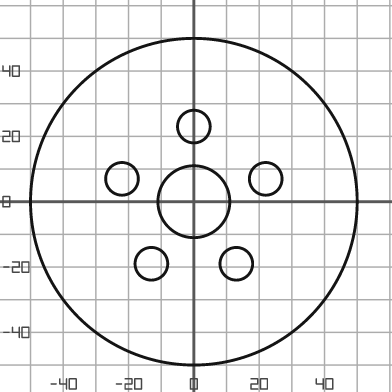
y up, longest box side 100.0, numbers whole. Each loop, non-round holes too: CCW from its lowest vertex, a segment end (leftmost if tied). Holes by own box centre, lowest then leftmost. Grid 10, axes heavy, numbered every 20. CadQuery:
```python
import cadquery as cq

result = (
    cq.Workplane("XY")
    .moveTo(0.0, 0.0)
    .circle(50.0)
    .moveTo(-13.0, -19.0)
    .circle(5.0)
    .moveTo(13.0, -19.0)
    .circle(5.0)
    .moveTo(0.0, 0.0)
    .circle(11.0)
    .moveTo(-22.0, 7.0)
    .circle(5.0)
    .moveTo(22.0, 7.0)
    .circle(5.0)
    .moveTo(0.0, 23.0)
    .circle(5.0)
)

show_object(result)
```